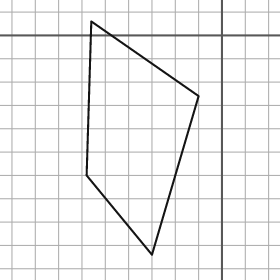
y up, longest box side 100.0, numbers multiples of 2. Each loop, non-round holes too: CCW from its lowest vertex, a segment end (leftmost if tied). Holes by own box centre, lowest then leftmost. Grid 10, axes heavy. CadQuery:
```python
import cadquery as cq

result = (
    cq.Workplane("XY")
    .moveTo(-30.0, -94.0)
    .lineTo(-10.0, -26.0)
    .lineTo(-56.0, 6.0)
    .lineTo(-58.0, -60.0)
    .close()
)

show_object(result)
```